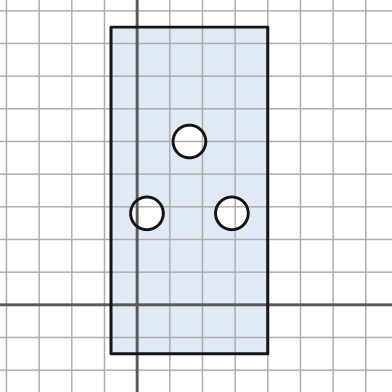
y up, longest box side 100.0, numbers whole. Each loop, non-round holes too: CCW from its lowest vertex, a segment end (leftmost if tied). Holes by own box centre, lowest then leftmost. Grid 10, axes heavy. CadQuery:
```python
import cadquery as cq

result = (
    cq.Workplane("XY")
    .moveTo(-8.0, -15.0)
    .lineTo(40.0, -15.0)
    .lineTo(40.0, 85.0)
    .lineTo(-8.0, 85.0)
    .close()
    .moveTo(3.0, 28.0)
    .circle(5.0)
    .moveTo(29.0, 28.0)
    .circle(5.0)
    .moveTo(16.0, 50.0)
    .circle(5.0)
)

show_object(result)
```